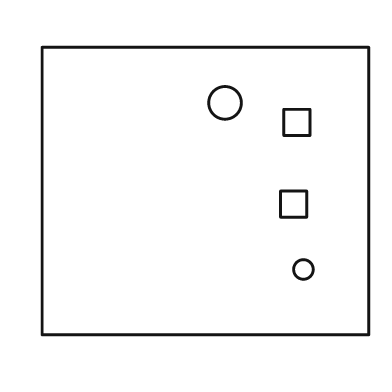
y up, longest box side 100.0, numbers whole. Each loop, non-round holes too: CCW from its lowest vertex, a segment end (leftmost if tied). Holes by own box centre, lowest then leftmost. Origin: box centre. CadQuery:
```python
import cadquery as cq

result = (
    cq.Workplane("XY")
    .moveTo(-50.0, -44.0)
    .lineTo(50.0, -44.0)
    .lineTo(50.0, 44.0)
    .lineTo(-50.0, 44.0)
    .close()
    .moveTo(30.0, -24.0)
    .circle(3.0)
    .moveTo(23.0, -8.0)
    .lineTo(31.0, -8.0)
    .lineTo(31.0, 0.0)
    .lineTo(23.0, 0.0)
    .close()
    .moveTo(24.0, 17.0)
    .lineTo(32.0, 17.0)
    .lineTo(32.0, 25.0)
    .lineTo(24.0, 25.0)
    .close()
    .moveTo(6.0, 27.0)
    .circle(5.0)
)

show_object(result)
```